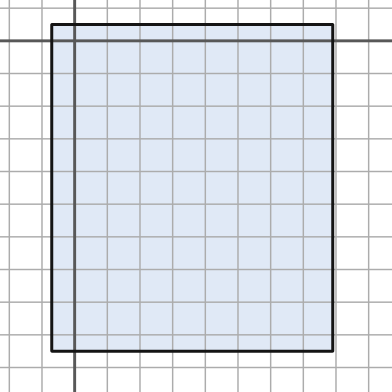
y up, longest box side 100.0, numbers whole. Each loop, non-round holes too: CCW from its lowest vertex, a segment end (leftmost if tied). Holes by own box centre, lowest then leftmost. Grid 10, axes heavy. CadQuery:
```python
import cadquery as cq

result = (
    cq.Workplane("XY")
    .moveTo(-7.0, -95.0)
    .lineTo(79.0, -95.0)
    .lineTo(79.0, 5.0)
    .lineTo(-7.0, 5.0)
    .close()
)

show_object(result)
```